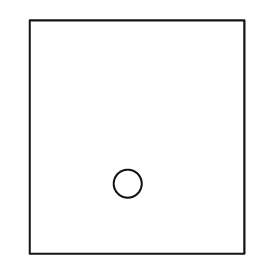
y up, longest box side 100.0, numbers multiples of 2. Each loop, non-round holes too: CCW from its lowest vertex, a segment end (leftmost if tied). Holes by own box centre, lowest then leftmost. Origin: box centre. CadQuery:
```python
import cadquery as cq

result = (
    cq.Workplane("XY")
    .moveTo(-46.0, -50.0)
    .lineTo(46.0, -50.0)
    .lineTo(46.0, 50.0)
    .lineTo(-46.0, 50.0)
    .close()
    .moveTo(-4.0, -20.0)
    .circle(6.0)
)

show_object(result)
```